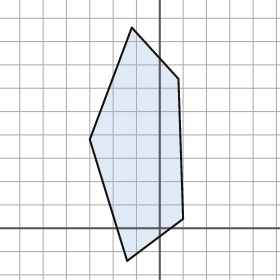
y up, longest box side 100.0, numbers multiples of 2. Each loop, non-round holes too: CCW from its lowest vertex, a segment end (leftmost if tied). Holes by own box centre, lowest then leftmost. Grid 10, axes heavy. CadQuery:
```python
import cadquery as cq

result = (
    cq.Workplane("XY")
    .moveTo(-14.0, -14.0)
    .lineTo(10.0, 4.0)
    .lineTo(8.0, 64.0)
    .lineTo(-12.0, 86.0)
    .lineTo(-30.0, 38.0)
    .close()
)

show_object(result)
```